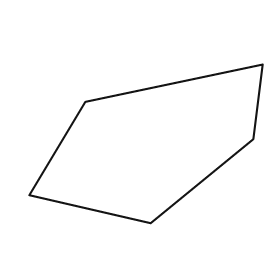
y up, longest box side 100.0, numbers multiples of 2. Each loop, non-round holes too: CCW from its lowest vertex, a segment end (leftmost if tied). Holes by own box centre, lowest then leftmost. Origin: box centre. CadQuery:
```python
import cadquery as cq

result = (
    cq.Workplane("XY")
    .moveTo(2.0, -34.0)
    .lineTo(46.0, 2.0)
    .lineTo(50.0, 34.0)
    .lineTo(-26.0, 18.0)
    .lineTo(-50.0, -22.0)
    .close()
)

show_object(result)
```